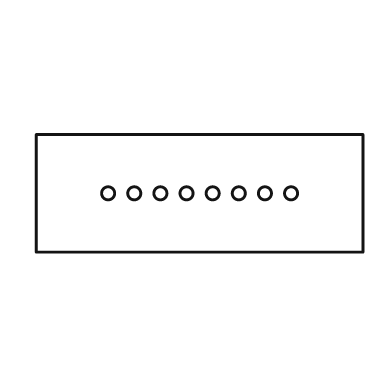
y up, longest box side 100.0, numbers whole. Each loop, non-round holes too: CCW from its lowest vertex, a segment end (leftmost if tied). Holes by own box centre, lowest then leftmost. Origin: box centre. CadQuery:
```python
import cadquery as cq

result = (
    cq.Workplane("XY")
    .moveTo(-50.0, -18.0)
    .lineTo(50.0, -18.0)
    .lineTo(50.0, 18.0)
    .lineTo(-50.0, 18.0)
    .close()
    .moveTo(-28.0, 0.0)
    .circle(2.0)
    .moveTo(-20.0, 0.0)
    .circle(2.0)
    .moveTo(-12.0, 0.0)
    .circle(2.0)
    .moveTo(-4.0, 0.0)
    .circle(2.0)
    .moveTo(4.0, 0.0)
    .circle(2.0)
    .moveTo(12.0, 0.0)
    .circle(2.0)
    .moveTo(20.0, 0.0)
    .circle(2.0)
    .moveTo(28.0, 0.0)
    .circle(2.0)
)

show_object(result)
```